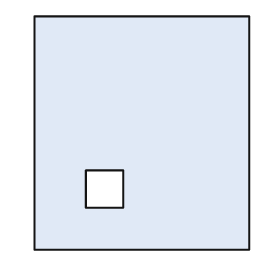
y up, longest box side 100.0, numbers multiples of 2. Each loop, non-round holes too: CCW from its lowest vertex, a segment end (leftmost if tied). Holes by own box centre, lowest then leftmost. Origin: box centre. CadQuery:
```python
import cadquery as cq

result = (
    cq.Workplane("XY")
    .moveTo(-46.0, -50.0)
    .lineTo(46.0, -50.0)
    .lineTo(46.0, 50.0)
    .lineTo(-46.0, 50.0)
    .close()
    .moveTo(-24.0, -32.0)
    .lineTo(-8.0, -32.0)
    .lineTo(-8.0, -16.0)
    .lineTo(-24.0, -16.0)
    .close()
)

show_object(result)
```